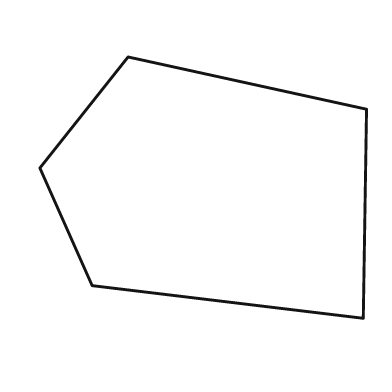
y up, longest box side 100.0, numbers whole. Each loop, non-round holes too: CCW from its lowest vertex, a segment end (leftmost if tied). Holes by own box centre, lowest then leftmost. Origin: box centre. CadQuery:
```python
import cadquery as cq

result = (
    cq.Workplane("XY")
    .moveTo(49.0, -40.0)
    .lineTo(50.0, 24.0)
    .lineTo(-23.0, 40.0)
    .lineTo(-50.0, 6.0)
    .lineTo(-34.0, -30.0)
    .close()
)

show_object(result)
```